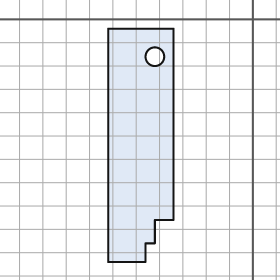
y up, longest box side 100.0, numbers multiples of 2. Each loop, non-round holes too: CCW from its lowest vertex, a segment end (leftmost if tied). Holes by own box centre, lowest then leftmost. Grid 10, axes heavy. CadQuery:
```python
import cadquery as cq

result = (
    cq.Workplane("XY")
    .moveTo(-62.0, -104.0)
    .lineTo(-46.0, -104.0)
    .lineTo(-46.0, -96.0)
    .lineTo(-42.0, -96.0)
    .lineTo(-42.0, -86.0)
    .lineTo(-34.0, -86.0)
    .lineTo(-34.0, -4.0)
    .lineTo(-62.0, -4.0)
    .close()
    .moveTo(-42.0, -16.0)
    .circle(4.0)
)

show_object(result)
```